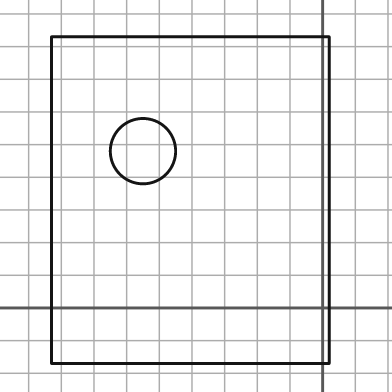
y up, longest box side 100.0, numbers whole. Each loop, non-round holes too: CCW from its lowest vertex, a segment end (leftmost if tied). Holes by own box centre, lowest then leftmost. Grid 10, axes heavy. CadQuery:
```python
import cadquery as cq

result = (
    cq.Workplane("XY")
    .moveTo(-83.0, -17.0)
    .lineTo(2.0, -17.0)
    .lineTo(2.0, 83.0)
    .lineTo(-83.0, 83.0)
    .close()
    .moveTo(-55.0, 48.0)
    .circle(10.0)
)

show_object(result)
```